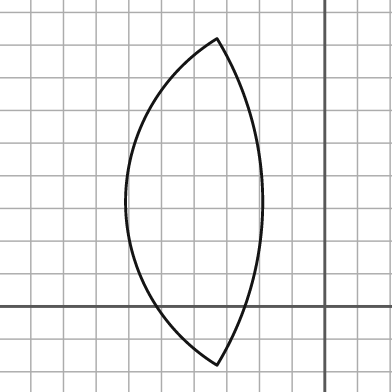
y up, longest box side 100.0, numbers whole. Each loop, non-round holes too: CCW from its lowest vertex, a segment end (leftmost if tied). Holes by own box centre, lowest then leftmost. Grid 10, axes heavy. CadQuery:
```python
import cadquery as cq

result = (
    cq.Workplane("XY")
    .moveTo(-33.0, -18.0)
    .threePointArc((-19.0, 32.0), (-33.0, 82.0))
    .threePointArc((-61.0, 32.0), (-33.0, -18.0))
    .close()
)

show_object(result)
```